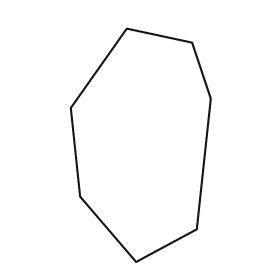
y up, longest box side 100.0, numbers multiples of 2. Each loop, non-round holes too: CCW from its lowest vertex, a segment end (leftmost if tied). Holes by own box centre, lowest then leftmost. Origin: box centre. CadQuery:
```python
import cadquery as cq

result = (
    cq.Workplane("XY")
    .moveTo(-2.0, -50.0)
    .lineTo(24.0, -36.0)
    .lineTo(30.0, 20.0)
    .lineTo(22.0, 44.0)
    .lineTo(-6.0, 50.0)
    .lineTo(-30.0, 16.0)
    .lineTo(-26.0, -22.0)
    .close()
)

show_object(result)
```